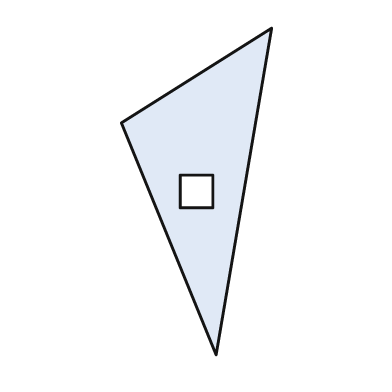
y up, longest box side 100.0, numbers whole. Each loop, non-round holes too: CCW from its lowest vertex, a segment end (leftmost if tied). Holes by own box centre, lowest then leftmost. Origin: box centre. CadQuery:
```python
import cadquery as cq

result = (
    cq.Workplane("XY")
    .moveTo(6.0, -50.0)
    .lineTo(23.0, 50.0)
    .lineTo(-23.0, 21.0)
    .close()
    .moveTo(-5.0, -5.0)
    .lineTo(5.0, -5.0)
    .lineTo(5.0, 5.0)
    .lineTo(-5.0, 5.0)
    .close()
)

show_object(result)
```